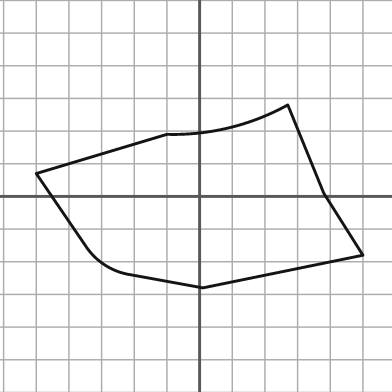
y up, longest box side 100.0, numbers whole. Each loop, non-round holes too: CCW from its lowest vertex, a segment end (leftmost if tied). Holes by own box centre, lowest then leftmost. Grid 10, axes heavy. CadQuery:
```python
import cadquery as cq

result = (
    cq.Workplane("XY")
    .moveTo(1.0, -28.0)
    .lineTo(50.0, -18.0)
    .lineTo(38.0, 1.0)
    .lineTo(27.0, 28.0)
    .threePointArc((9.0, 21.0), (-10.0, 19.0))
    .lineTo(-50.0, 7.0)
    .lineTo(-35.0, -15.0)
    .threePointArc((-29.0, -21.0), (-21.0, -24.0))
    .close()
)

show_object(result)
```